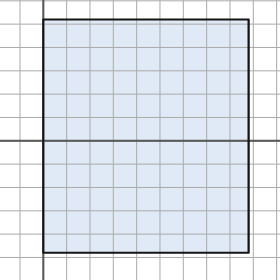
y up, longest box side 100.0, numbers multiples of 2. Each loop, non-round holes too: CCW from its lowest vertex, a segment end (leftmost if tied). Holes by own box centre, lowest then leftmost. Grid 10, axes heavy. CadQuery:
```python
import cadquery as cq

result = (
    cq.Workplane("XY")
    .moveTo(0.0, -48.0)
    .lineTo(88.0, -48.0)
    .lineTo(88.0, 52.0)
    .lineTo(0.0, 52.0)
    .close()
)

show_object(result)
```